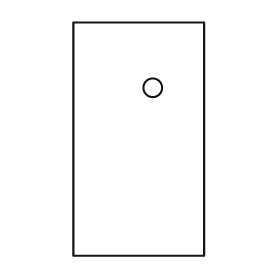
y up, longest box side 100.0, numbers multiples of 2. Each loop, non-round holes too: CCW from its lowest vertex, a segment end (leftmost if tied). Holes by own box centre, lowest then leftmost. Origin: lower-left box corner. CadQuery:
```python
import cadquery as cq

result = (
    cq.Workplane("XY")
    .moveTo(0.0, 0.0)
    .lineTo(56.0, 0.0)
    .lineTo(56.0, 100.0)
    .lineTo(0.0, 100.0)
    .close()
    .moveTo(34.0, 72.0)
    .circle(4.0)
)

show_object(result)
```